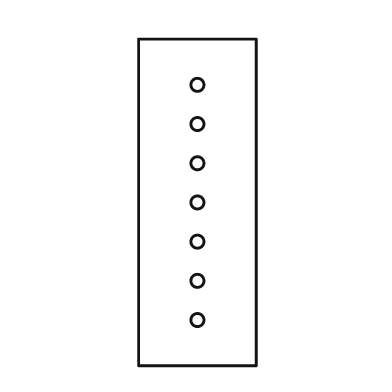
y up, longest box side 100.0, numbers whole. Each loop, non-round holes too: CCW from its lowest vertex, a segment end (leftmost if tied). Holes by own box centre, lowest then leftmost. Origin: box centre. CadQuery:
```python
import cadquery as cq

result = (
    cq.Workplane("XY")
    .moveTo(-18.0, -50.0)
    .lineTo(18.0, -50.0)
    .lineTo(18.0, 50.0)
    .lineTo(-18.0, 50.0)
    .close()
    .moveTo(0.0, -36.0)
    .circle(2.0)
    .moveTo(0.0, -24.0)
    .circle(2.0)
    .moveTo(0.0, -12.0)
    .circle(2.0)
    .moveTo(0.0, 0.0)
    .circle(2.0)
    .moveTo(0.0, 12.0)
    .circle(2.0)
    .moveTo(0.0, 24.0)
    .circle(2.0)
    .moveTo(0.0, 36.0)
    .circle(2.0)
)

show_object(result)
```